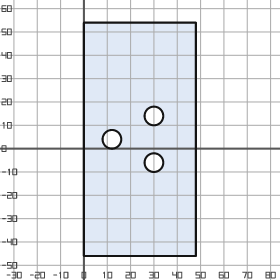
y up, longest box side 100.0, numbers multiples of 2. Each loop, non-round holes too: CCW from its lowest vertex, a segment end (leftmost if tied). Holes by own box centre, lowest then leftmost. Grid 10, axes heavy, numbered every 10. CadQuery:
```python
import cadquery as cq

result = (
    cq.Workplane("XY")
    .moveTo(0.0, -46.0)
    .lineTo(48.0, -46.0)
    .lineTo(48.0, 54.0)
    .lineTo(0.0, 54.0)
    .close()
    .moveTo(30.0, -6.0)
    .circle(4.0)
    .moveTo(12.0, 4.0)
    .circle(4.0)
    .moveTo(30.0, 14.0)
    .circle(4.0)
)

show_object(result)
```